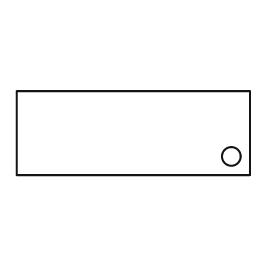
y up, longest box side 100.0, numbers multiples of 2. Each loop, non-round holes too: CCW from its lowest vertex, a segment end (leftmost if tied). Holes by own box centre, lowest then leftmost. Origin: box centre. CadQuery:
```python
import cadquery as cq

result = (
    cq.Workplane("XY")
    .moveTo(-50.0, -18.0)
    .lineTo(50.0, -18.0)
    .lineTo(50.0, 18.0)
    .lineTo(-50.0, 18.0)
    .close()
    .moveTo(42.0, -10.0)
    .circle(4.0)
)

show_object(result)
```